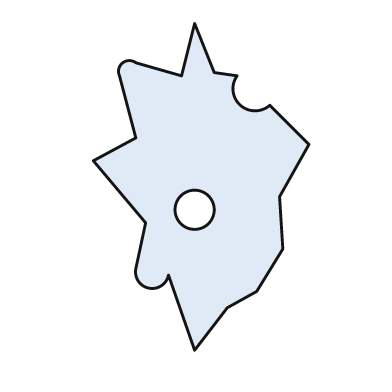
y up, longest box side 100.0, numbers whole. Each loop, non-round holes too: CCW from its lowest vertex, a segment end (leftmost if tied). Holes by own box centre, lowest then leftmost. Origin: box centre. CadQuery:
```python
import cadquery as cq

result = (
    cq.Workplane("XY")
    .moveTo(-2.0, -50.0)
    .lineTo(8.0, -37.0)
    .lineTo(17.0, -32.0)
    .lineTo(25.0, -19.0)
    .lineTo(24.0, -3.0)
    .lineTo(33.0, 13.0)
    .lineTo(21.0, 25.0)
    .threePointArc((12.0, 25.0), (11.0, 34.0))
    .lineTo(4.0, 35.0)
    .lineTo(-2.0, 50.0)
    .lineTo(-6.0, 34.0)
    .lineTo(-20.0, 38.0)
    .threePointArc((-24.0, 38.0), (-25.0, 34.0))
    .lineTo(-20.0, 15.0)
    .lineTo(-33.0, 8.0)
    .lineTo(-17.0, -11.0)
    .lineTo(-20.0, -25.0)
    .threePointArc((-16.0, -31.0), (-10.0, -27.0))
    .close()
    .moveTo(-2.0, -7.0)
    .circle(6.0)
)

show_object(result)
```